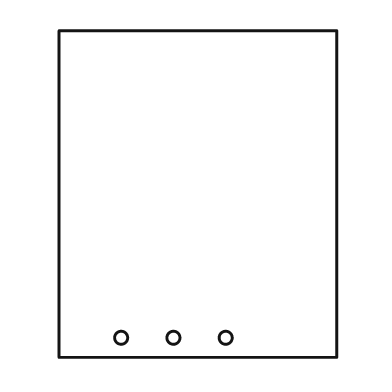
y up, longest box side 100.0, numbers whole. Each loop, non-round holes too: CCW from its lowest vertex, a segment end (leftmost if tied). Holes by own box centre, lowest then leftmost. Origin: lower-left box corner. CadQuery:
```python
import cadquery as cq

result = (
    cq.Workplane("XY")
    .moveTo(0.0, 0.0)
    .lineTo(85.0, 0.0)
    .lineTo(85.0, 100.0)
    .lineTo(0.0, 100.0)
    .close()
    .moveTo(19.0, 6.0)
    .circle(2.0)
    .moveTo(35.0, 6.0)
    .circle(2.0)
    .moveTo(51.0, 6.0)
    .circle(2.0)
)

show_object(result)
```